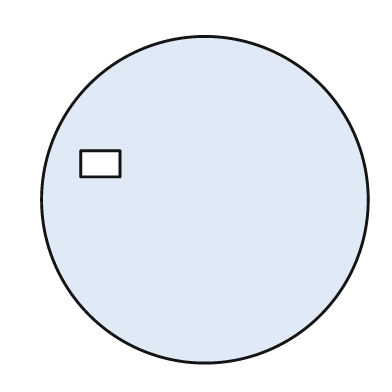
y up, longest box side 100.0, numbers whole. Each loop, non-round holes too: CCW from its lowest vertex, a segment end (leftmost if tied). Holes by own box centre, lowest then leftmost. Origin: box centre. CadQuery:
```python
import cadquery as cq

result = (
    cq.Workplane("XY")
    .moveTo(0.0, 0.0)
    .circle(50.0)
    .moveTo(-38.0, 7.0)
    .lineTo(-26.0, 7.0)
    .lineTo(-26.0, 15.0)
    .lineTo(-38.0, 15.0)
    .close()
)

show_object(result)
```